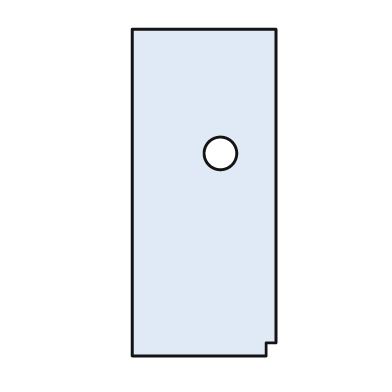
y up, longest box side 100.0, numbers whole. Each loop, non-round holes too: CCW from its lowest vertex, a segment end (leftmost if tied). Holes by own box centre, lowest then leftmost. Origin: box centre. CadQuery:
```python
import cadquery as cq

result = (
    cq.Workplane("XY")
    .moveTo(-22.0, -50.0)
    .lineTo(19.0, -50.0)
    .lineTo(19.0, -46.0)
    .lineTo(22.0, -46.0)
    .lineTo(22.0, 50.0)
    .lineTo(-22.0, 50.0)
    .close()
    .moveTo(5.0, 12.0)
    .circle(5.0)
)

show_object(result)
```